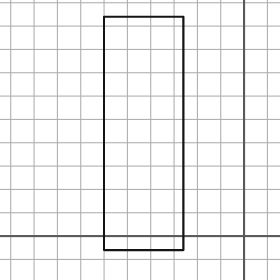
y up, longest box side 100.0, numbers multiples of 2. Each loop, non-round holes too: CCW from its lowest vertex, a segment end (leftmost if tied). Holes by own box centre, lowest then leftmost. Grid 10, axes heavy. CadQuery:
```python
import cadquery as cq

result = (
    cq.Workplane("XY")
    .moveTo(-60.0, -6.0)
    .lineTo(-26.0, -6.0)
    .lineTo(-26.0, 94.0)
    .lineTo(-60.0, 94.0)
    .close()
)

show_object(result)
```